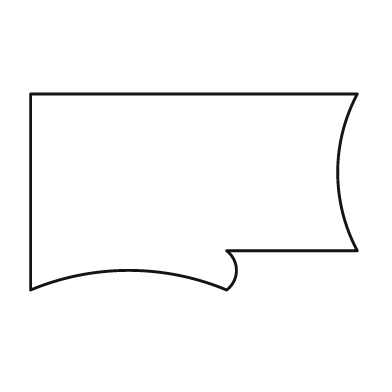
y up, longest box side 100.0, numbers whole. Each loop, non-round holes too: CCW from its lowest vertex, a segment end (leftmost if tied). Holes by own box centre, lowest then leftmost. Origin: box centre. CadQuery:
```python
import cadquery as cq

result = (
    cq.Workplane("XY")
    .moveTo(-50.0, -30.0)
    .threePointArc((-20.0, -24.0), (10.0, -30.0))
    .threePointArc((13.0, -24.0), (10.0, -18.0))
    .lineTo(50.0, -18.0)
    .threePointArc((44.0, 6.0), (50.0, 30.0))
    .lineTo(-50.0, 30.0)
    .close()
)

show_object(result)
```